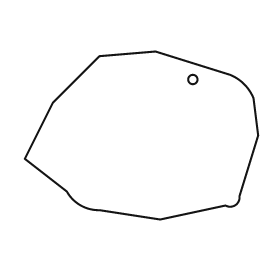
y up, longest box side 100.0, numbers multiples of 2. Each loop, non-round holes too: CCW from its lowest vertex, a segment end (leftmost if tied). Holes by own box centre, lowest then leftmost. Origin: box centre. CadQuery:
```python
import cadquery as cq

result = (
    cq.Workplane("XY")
    .moveTo(8.0, -36.0)
    .lineTo(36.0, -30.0)
    .threePointArc((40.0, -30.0), (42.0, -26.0))
    .lineTo(50.0, 0.0)
    .lineTo(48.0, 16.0)
    .threePointArc((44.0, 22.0), (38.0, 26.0))
    .lineTo(6.0, 36.0)
    .lineTo(-18.0, 34.0)
    .lineTo(-38.0, 14.0)
    .lineTo(-50.0, -10.0)
    .lineTo(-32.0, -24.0)
    .threePointArc((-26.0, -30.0), (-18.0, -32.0))
    .close()
    .moveTo(22.0, 24.0)
    .circle(2.0)
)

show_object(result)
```